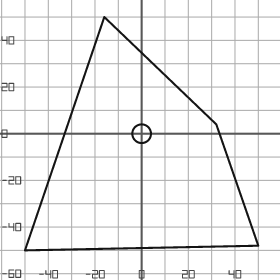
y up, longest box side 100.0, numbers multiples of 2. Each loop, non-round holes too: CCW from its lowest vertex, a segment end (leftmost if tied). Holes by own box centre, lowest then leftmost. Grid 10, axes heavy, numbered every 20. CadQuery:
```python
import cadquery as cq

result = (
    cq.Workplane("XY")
    .moveTo(-50.0, -50.0)
    .lineTo(50.0, -48.0)
    .lineTo(32.0, 4.0)
    .lineTo(-16.0, 50.0)
    .close()
    .moveTo(0.0, 0.0)
    .circle(4.0)
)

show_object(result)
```